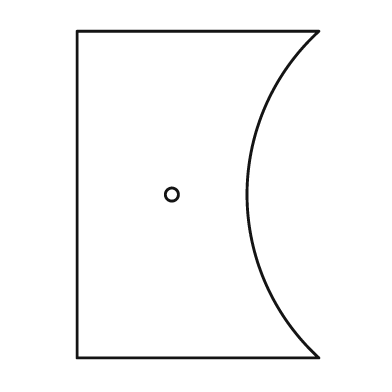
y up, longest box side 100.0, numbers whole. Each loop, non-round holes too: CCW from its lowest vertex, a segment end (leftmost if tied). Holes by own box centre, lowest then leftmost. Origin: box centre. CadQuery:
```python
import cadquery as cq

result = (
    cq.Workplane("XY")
    .moveTo(-37.0, -50.0)
    .lineTo(37.0, -50.0)
    .threePointArc((15.0, 0.0), (37.0, 50.0))
    .lineTo(-37.0, 50.0)
    .close()
    .moveTo(-8.0, 0.0)
    .circle(2.0)
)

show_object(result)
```